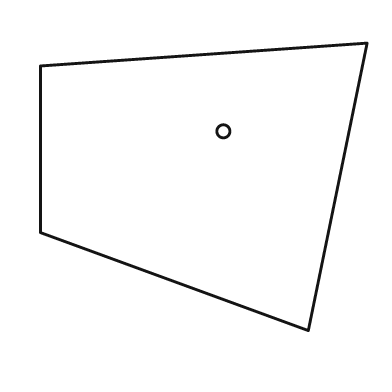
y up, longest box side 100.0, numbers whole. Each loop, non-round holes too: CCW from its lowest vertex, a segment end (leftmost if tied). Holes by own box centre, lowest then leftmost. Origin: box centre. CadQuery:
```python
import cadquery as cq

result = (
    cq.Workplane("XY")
    .moveTo(32.0, -44.0)
    .lineTo(50.0, 44.0)
    .lineTo(-50.0, 37.0)
    .lineTo(-50.0, -14.0)
    .close()
    .moveTo(6.0, 17.0)
    .circle(2.0)
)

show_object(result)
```